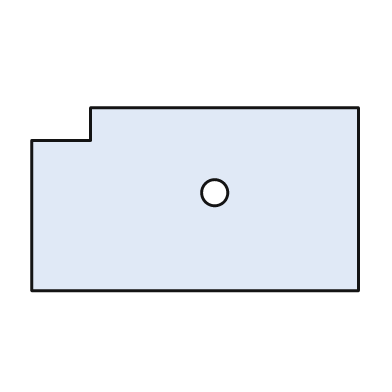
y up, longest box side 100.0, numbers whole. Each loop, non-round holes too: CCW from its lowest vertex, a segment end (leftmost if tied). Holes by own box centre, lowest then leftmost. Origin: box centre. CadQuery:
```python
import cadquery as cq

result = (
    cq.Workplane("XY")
    .moveTo(-50.0, -28.0)
    .lineTo(50.0, -28.0)
    .lineTo(50.0, 28.0)
    .lineTo(-32.0, 28.0)
    .lineTo(-32.0, 18.0)
    .lineTo(-50.0, 18.0)
    .close()
    .moveTo(6.0, 2.0)
    .circle(4.0)
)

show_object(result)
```